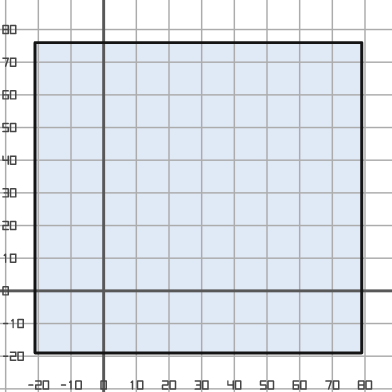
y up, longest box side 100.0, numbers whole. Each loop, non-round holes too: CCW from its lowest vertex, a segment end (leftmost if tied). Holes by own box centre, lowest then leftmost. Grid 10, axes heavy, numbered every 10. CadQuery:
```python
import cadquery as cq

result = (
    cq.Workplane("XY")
    .moveTo(-21.0, -19.0)
    .lineTo(79.0, -19.0)
    .lineTo(79.0, 76.0)
    .lineTo(-21.0, 76.0)
    .close()
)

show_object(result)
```